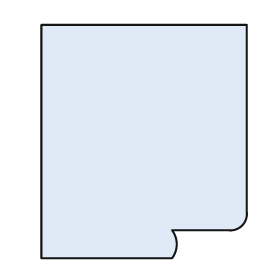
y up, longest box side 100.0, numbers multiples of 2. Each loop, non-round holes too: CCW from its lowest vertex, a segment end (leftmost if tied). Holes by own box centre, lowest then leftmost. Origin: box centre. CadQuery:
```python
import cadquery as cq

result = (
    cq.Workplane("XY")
    .moveTo(-44.0, -50.0)
    .lineTo(12.0, -50.0)
    .threePointArc((14.0, -44.0), (12.0, -38.0))
    .lineTo(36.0, -38.0)
    .threePointArc((42.0, -36.0), (44.0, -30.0))
    .lineTo(44.0, 50.0)
    .lineTo(-44.0, 50.0)
    .close()
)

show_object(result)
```